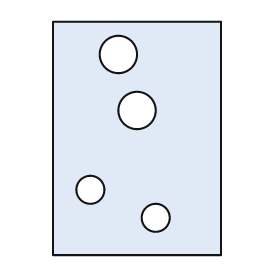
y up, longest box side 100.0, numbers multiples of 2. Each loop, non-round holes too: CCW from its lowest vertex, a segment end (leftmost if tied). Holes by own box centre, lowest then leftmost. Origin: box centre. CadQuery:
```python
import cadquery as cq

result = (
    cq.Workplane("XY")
    .moveTo(-36.0, -50.0)
    .lineTo(36.0, -50.0)
    .lineTo(36.0, 50.0)
    .lineTo(-36.0, 50.0)
    .close()
    .moveTo(8.0, -34.0)
    .circle(6.0)
    .moveTo(-20.0, -22.0)
    .circle(6.0)
    .moveTo(0.0, 12.0)
    .circle(8.0)
    .moveTo(-8.0, 36.0)
    .circle(8.0)
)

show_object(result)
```